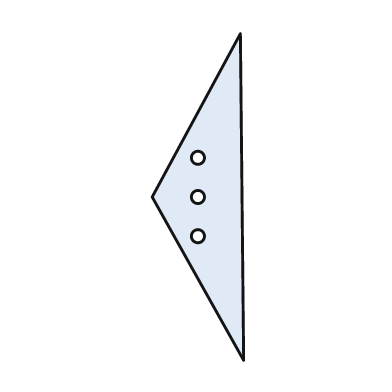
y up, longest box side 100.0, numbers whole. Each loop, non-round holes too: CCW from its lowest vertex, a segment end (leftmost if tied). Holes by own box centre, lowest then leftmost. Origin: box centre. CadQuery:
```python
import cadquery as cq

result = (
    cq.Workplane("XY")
    .moveTo(14.0, -50.0)
    .lineTo(13.0, 50.0)
    .lineTo(-14.0, 0.0)
    .close()
    .moveTo(0.0, -12.0)
    .circle(2.0)
    .moveTo(0.0, 0.0)
    .circle(2.0)
    .moveTo(0.0, 12.0)
    .circle(2.0)
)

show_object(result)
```